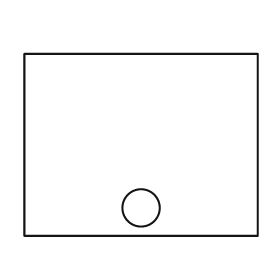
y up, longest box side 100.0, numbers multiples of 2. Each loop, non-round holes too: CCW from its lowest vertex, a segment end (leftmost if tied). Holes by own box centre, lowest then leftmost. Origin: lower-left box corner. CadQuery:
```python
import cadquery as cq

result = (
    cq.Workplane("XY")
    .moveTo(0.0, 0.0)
    .lineTo(100.0, 0.0)
    .lineTo(100.0, 78.0)
    .lineTo(0.0, 78.0)
    .close()
    .moveTo(50.0, 12.0)
    .circle(8.0)
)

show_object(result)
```